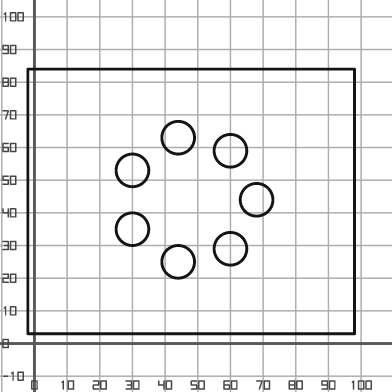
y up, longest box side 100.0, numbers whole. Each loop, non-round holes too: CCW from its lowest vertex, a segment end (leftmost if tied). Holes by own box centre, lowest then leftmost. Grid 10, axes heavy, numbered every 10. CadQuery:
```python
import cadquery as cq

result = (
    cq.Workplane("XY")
    .moveTo(-2.0, 3.0)
    .lineTo(98.0, 3.0)
    .lineTo(98.0, 84.0)
    .lineTo(-2.0, 84.0)
    .close()
    .moveTo(44.0, 25.0)
    .circle(5.0)
    .moveTo(60.0, 29.0)
    .circle(5.0)
    .moveTo(30.0, 35.0)
    .circle(5.0)
    .moveTo(68.0, 44.0)
    .circle(5.0)
    .moveTo(30.0, 53.0)
    .circle(5.0)
    .moveTo(60.0, 59.0)
    .circle(5.0)
    .moveTo(44.0, 63.0)
    .circle(5.0)
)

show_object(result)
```